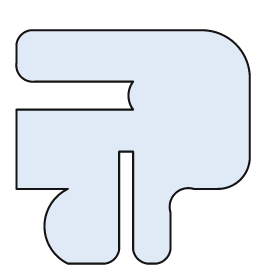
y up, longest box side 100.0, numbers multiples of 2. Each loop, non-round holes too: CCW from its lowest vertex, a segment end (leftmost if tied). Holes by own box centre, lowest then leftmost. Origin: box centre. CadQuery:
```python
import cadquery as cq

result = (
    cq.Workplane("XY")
    .moveTo(-28.0, -50.0)
    .lineTo(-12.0, -50.0)
    .threePointArc((-8.0, -48.0), (-6.0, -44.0))
    .lineTo(-6.0, -2.0)
    .lineTo(0.0, -2.0)
    .lineTo(0.0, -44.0)
    .threePointArc((2.0, -48.0), (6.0, -50.0))
    .lineTo(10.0, -50.0)
    .threePointArc((14.0, -48.0), (16.0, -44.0))
    .lineTo(16.0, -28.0)
    .threePointArc((18.0, -20.0), (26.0, -18.0))
    .lineTo(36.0, -18.0)
    .threePointArc((46.0, -14.0), (50.0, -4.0))
    .lineTo(50.0, 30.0)
    .threePointArc((44.0, 44.0), (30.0, 50.0))
    .lineTo(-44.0, 50.0)
    .threePointArc((-48.0, 48.0), (-50.0, 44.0))
    .lineTo(-50.0, 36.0)
    .threePointArc((-48.0, 30.0), (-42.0, 28.0))
    .lineTo(0.0, 28.0)
    .threePointArc((-2.0, 22.0), (0.0, 16.0))
    .lineTo(-50.0, 16.0)
    .lineTo(-50.0, -18.0)
    .lineTo(-28.0, -18.0)
    .threePointArc((-38.0, -34.0), (-28.0, -50.0))
    .close()
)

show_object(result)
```